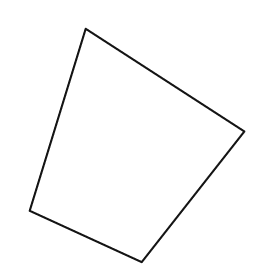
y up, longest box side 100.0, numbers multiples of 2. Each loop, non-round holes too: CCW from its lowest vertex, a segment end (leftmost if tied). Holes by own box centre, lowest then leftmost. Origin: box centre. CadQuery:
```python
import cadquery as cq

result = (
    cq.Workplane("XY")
    .moveTo(2.0, -50.0)
    .lineTo(46.0, 6.0)
    .lineTo(-22.0, 50.0)
    .lineTo(-46.0, -28.0)
    .close()
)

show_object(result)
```